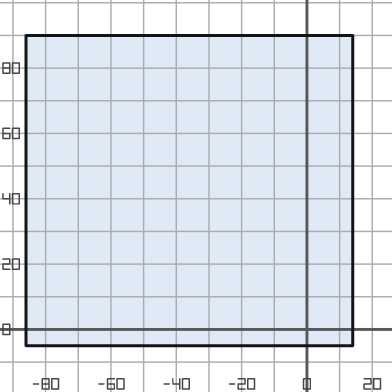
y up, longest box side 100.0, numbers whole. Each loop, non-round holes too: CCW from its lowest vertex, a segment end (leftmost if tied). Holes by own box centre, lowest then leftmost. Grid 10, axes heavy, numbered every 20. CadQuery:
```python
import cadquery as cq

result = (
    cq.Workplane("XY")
    .moveTo(-86.0, -5.0)
    .lineTo(14.0, -5.0)
    .lineTo(14.0, 90.0)
    .lineTo(-86.0, 90.0)
    .close()
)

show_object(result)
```